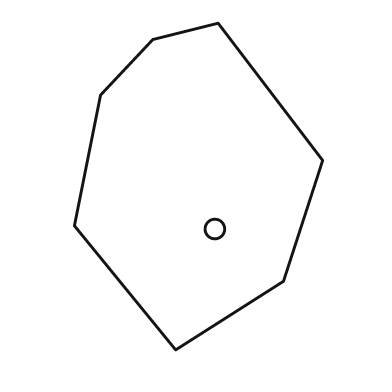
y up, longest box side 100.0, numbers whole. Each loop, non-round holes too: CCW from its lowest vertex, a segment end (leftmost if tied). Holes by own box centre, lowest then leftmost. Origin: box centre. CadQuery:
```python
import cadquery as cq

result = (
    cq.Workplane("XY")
    .moveTo(-7.0, -50.0)
    .lineTo(26.0, -29.0)
    .lineTo(38.0, 8.0)
    .lineTo(6.0, 50.0)
    .lineTo(-14.0, 45.0)
    .lineTo(-30.0, 28.0)
    .lineTo(-38.0, -12.0)
    .close()
    .moveTo(5.0, -13.0)
    .circle(3.0)
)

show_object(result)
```